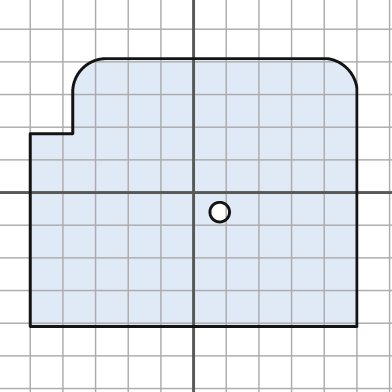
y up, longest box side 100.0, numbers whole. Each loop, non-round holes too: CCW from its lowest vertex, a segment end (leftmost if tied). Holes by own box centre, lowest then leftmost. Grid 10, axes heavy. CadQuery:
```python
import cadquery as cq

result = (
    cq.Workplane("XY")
    .moveTo(-50.0, -41.0)
    .lineTo(50.0, -41.0)
    .lineTo(50.0, 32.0)
    .threePointArc((47.0, 38.0), (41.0, 41.0))
    .lineTo(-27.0, 41.0)
    .threePointArc((-34.0, 38.0), (-37.0, 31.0))
    .lineTo(-37.0, 18.0)
    .lineTo(-50.0, 18.0)
    .close()
    .moveTo(8.0, -6.0)
    .circle(3.0)
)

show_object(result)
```